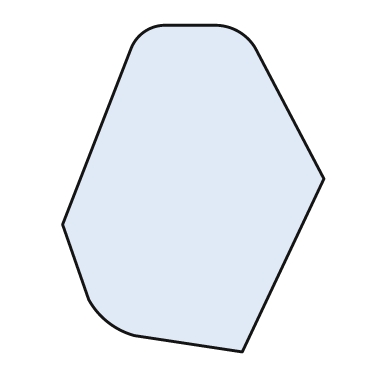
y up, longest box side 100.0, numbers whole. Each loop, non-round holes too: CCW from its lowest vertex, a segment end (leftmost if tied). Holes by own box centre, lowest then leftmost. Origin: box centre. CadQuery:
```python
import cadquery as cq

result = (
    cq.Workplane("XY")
    .moveTo(15.0, -50.0)
    .lineTo(40.0, 3.0)
    .lineTo(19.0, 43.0)
    .threePointArc((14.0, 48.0), (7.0, 50.0))
    .lineTo(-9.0, 50.0)
    .threePointArc((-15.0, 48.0), (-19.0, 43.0))
    .lineTo(-40.0, -11.0)
    .lineTo(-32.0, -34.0)
    .threePointArc((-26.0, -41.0), (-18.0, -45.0))
    .close()
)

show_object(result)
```